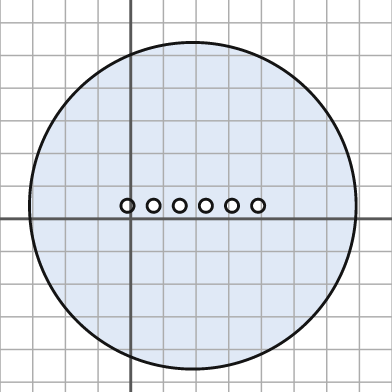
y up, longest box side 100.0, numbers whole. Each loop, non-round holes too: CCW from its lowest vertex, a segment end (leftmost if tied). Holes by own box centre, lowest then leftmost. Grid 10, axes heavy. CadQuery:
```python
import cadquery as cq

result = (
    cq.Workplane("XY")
    .moveTo(19.0, 4.0)
    .circle(50.0)
    .moveTo(-1.0, 4.0)
    .circle(2.0)
    .moveTo(7.0, 4.0)
    .circle(2.0)
    .moveTo(15.0, 4.0)
    .circle(2.0)
    .moveTo(23.0, 4.0)
    .circle(2.0)
    .moveTo(31.0, 4.0)
    .circle(2.0)
    .moveTo(39.0, 4.0)
    .circle(2.0)
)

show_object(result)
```